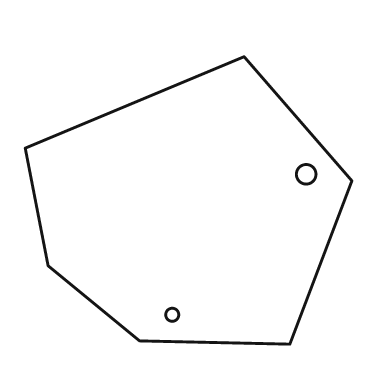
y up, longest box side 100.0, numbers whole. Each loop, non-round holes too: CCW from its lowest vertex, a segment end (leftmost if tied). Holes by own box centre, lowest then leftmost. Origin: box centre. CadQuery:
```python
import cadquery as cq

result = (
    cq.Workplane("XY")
    .moveTo(31.0, -44.0)
    .lineTo(50.0, 6.0)
    .lineTo(17.0, 44.0)
    .lineTo(-50.0, 16.0)
    .lineTo(-43.0, -20.0)
    .lineTo(-15.0, -43.0)
    .close()
    .moveTo(-5.0, -35.0)
    .circle(2.0)
    .moveTo(36.0, 8.0)
    .circle(3.0)
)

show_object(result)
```